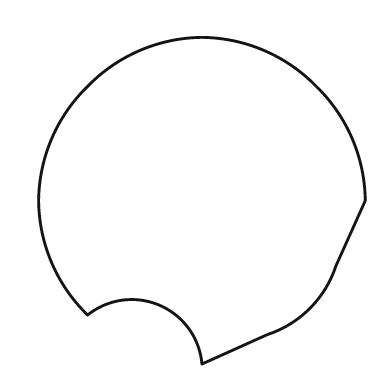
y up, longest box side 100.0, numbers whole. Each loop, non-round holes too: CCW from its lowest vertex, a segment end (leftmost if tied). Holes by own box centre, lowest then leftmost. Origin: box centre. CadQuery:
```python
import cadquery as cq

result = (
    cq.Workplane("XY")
    .moveTo(0.0, -50.0)
    .lineTo(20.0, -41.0)
    .threePointArc((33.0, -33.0), (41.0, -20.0))
    .lineTo(50.0, 0.0)
    .threePointArc((46.0, 19.0), (35.0, 35.0))
    .threePointArc((19.0, 46.0), (0.0, 50.0))
    .threePointArc((-19.0, 46.0), (-35.0, 35.0))
    .threePointArc((-46.0, 19.0), (-50.0, 0.0))
    .threePointArc((-46.0, -19.0), (-35.0, -35.0))
    .threePointArc((-13.0, -32.0), (0.0, -50.0))
    .close()
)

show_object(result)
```